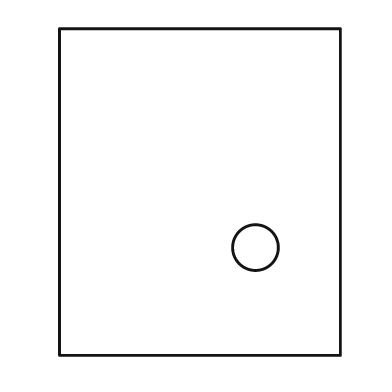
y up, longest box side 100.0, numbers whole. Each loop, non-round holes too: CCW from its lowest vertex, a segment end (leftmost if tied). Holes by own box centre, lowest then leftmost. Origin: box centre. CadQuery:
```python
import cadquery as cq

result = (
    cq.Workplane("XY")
    .moveTo(-43.0, -50.0)
    .lineTo(43.0, -50.0)
    .lineTo(43.0, 50.0)
    .lineTo(-43.0, 50.0)
    .close()
    .moveTo(17.0, -17.0)
    .circle(7.0)
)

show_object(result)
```